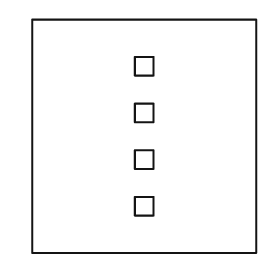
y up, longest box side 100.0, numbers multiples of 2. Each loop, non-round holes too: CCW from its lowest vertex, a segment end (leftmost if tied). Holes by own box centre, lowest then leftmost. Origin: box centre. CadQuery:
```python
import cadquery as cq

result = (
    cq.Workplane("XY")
    .moveTo(-48.0, -50.0)
    .lineTo(48.0, -50.0)
    .lineTo(48.0, 50.0)
    .lineTo(-48.0, 50.0)
    .close()
    .moveTo(-4.0, -34.0)
    .lineTo(4.0, -34.0)
    .lineTo(4.0, -26.0)
    .lineTo(-4.0, -26.0)
    .close()
    .moveTo(-4.0, -14.0)
    .lineTo(4.0, -14.0)
    .lineTo(4.0, -6.0)
    .lineTo(-4.0, -6.0)
    .close()
    .moveTo(-4.0, 6.0)
    .lineTo(4.0, 6.0)
    .lineTo(4.0, 14.0)
    .lineTo(-4.0, 14.0)
    .close()
    .moveTo(-4.0, 26.0)
    .lineTo(4.0, 26.0)
    .lineTo(4.0, 34.0)
    .lineTo(-4.0, 34.0)
    .close()
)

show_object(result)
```